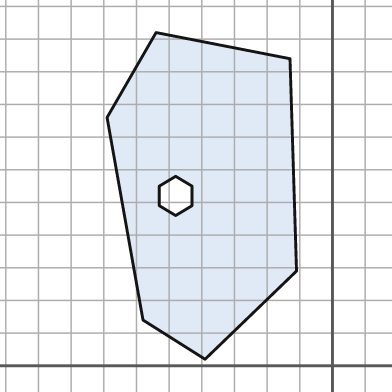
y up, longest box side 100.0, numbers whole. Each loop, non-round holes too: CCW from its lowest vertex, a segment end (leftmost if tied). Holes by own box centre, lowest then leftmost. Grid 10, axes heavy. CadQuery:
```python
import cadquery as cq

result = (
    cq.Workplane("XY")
    .moveTo(-39.0, 2.0)
    .lineTo(-11.0, 29.0)
    .lineTo(-13.0, 94.0)
    .lineTo(-54.0, 102.0)
    .lineTo(-69.0, 76.0)
    .lineTo(-58.0, 14.0)
    .close()
    .moveTo(-48.0, 46.0)
    .lineTo(-43.0, 49.0)
    .lineTo(-43.0, 55.0)
    .lineTo(-48.0, 58.0)
    .lineTo(-53.0, 55.0)
    .lineTo(-53.0, 49.0)
    .close()
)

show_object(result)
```